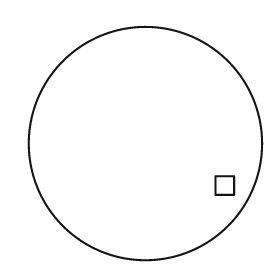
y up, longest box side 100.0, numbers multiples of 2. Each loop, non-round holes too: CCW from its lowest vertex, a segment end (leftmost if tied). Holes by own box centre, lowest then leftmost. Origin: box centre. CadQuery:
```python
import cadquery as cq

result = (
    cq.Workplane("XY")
    .moveTo(0.0, 0.0)
    .circle(50.0)
    .moveTo(30.0, -22.0)
    .lineTo(38.0, -22.0)
    .lineTo(38.0, -14.0)
    .lineTo(30.0, -14.0)
    .close()
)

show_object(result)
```